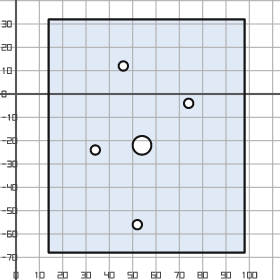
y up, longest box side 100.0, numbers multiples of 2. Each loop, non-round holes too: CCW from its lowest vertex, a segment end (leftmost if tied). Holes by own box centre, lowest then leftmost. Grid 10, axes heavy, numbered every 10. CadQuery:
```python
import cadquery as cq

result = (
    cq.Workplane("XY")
    .moveTo(14.0, -68.0)
    .lineTo(98.0, -68.0)
    .lineTo(98.0, 32.0)
    .lineTo(14.0, 32.0)
    .close()
    .moveTo(52.0, -56.0)
    .circle(2.0)
    .moveTo(34.0, -24.0)
    .circle(2.0)
    .moveTo(54.0, -22.0)
    .circle(4.0)
    .moveTo(74.0, -4.0)
    .circle(2.0)
    .moveTo(46.0, 12.0)
    .circle(2.0)
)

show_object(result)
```